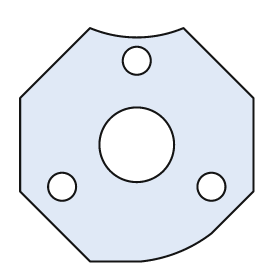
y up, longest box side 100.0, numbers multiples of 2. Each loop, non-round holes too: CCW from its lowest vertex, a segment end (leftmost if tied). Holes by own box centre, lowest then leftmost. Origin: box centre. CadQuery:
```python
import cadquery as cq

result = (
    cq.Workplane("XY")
    .moveTo(-20.0, -50.0)
    .lineTo(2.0, -50.0)
    .threePointArc((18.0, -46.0), (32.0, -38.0))
    .lineTo(50.0, -20.0)
    .lineTo(50.0, 20.0)
    .lineTo(20.0, 50.0)
    .threePointArc((0.0, 46.0), (-20.0, 50.0))
    .lineTo(-50.0, 20.0)
    .lineTo(-50.0, -20.0)
    .close()
    .moveTo(-32.0, -18.0)
    .circle(6.0)
    .moveTo(32.0, -18.0)
    .circle(6.0)
    .moveTo(0.0, 0.0)
    .circle(16.0)
    .moveTo(0.0, 36.0)
    .circle(6.0)
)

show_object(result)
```